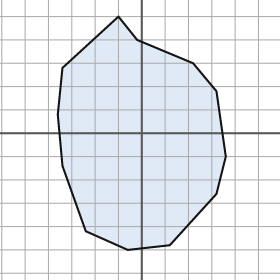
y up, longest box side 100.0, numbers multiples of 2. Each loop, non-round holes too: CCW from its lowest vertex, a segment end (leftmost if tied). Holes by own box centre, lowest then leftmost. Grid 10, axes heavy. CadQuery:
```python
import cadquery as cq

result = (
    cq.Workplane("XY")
    .moveTo(-6.0, -50.0)
    .lineTo(12.0, -48.0)
    .lineTo(32.0, -26.0)
    .lineTo(36.0, -10.0)
    .lineTo(32.0, 18.0)
    .lineTo(22.0, 30.0)
    .lineTo(-2.0, 40.0)
    .lineTo(-10.0, 50.0)
    .lineTo(-34.0, 28.0)
    .lineTo(-36.0, 8.0)
    .lineTo(-34.0, -14.0)
    .lineTo(-24.0, -42.0)
    .close()
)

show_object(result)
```